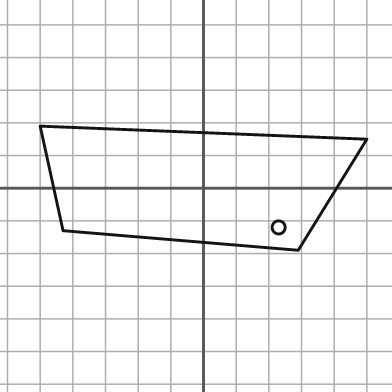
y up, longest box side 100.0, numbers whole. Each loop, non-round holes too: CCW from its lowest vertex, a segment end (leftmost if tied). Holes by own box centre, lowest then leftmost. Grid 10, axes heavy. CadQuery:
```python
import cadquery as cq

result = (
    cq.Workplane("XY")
    .moveTo(29.0, -19.0)
    .lineTo(50.0, 15.0)
    .lineTo(-50.0, 19.0)
    .lineTo(-43.0, -13.0)
    .close()
    .moveTo(23.0, -12.0)
    .circle(2.0)
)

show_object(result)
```